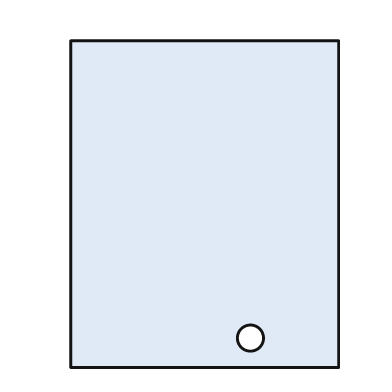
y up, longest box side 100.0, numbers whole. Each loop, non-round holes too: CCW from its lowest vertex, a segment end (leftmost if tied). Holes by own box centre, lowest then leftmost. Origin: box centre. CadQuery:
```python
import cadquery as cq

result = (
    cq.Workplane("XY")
    .moveTo(-41.0, -50.0)
    .lineTo(41.0, -50.0)
    .lineTo(41.0, 50.0)
    .lineTo(-41.0, 50.0)
    .close()
    .moveTo(14.0, -41.0)
    .circle(4.0)
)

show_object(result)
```